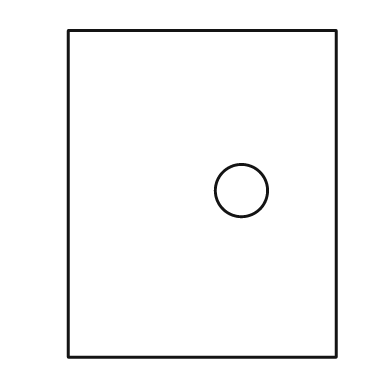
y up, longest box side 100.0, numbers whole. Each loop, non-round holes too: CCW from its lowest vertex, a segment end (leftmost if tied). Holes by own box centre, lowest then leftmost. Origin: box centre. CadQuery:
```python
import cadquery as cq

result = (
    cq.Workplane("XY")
    .moveTo(-41.0, -50.0)
    .lineTo(41.0, -50.0)
    .lineTo(41.0, 50.0)
    .lineTo(-41.0, 50.0)
    .close()
    .moveTo(12.0, 1.0)
    .circle(8.0)
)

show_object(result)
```